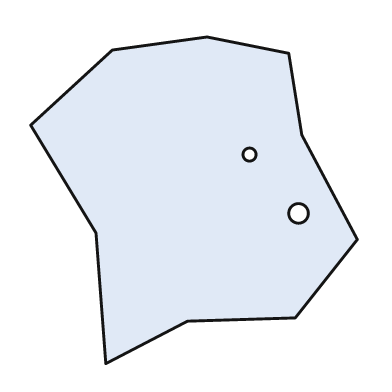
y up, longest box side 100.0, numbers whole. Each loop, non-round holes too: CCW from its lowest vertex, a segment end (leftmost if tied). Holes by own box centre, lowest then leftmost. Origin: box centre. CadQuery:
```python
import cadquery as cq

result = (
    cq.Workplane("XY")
    .moveTo(-27.0, -50.0)
    .lineTo(-2.0, -37.0)
    .lineTo(31.0, -36.0)
    .lineTo(50.0, -12.0)
    .lineTo(33.0, 20.0)
    .lineTo(29.0, 45.0)
    .lineTo(4.0, 50.0)
    .lineTo(-25.0, 46.0)
    .lineTo(-50.0, 23.0)
    .lineTo(-30.0, -10.0)
    .close()
    .moveTo(32.0, -4.0)
    .circle(3.0)
    .moveTo(17.0, 14.0)
    .circle(2.0)
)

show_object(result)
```